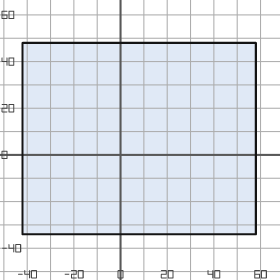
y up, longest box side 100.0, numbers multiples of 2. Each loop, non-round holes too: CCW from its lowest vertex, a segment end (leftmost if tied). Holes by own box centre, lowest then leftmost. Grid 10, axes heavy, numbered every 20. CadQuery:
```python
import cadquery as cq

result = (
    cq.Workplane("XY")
    .moveTo(-42.0, -34.0)
    .lineTo(58.0, -34.0)
    .lineTo(58.0, 48.0)
    .lineTo(-42.0, 48.0)
    .close()
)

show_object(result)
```